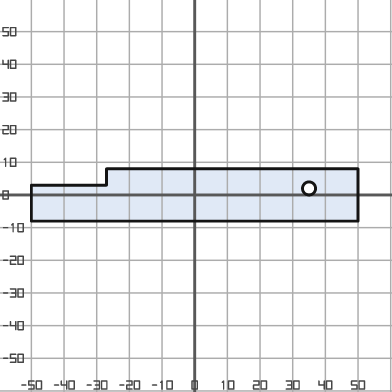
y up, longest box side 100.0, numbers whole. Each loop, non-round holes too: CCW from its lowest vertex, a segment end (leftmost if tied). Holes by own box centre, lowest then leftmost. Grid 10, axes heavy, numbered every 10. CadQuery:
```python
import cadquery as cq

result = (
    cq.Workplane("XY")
    .moveTo(-50.0, -8.0)
    .lineTo(50.0, -8.0)
    .lineTo(50.0, 8.0)
    .lineTo(-27.0, 8.0)
    .lineTo(-27.0, 3.0)
    .lineTo(-50.0, 3.0)
    .close()
    .moveTo(35.0, 2.0)
    .circle(2.0)
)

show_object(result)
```